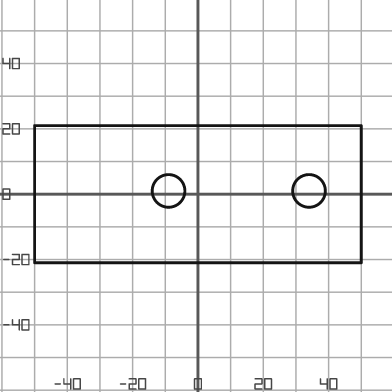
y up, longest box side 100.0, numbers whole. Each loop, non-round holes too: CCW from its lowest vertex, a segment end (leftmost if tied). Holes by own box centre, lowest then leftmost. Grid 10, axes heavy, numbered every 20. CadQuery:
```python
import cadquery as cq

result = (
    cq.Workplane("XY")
    .moveTo(-50.0, -21.0)
    .lineTo(50.0, -21.0)
    .lineTo(50.0, 21.0)
    .lineTo(-50.0, 21.0)
    .close()
    .moveTo(-9.0, 1.0)
    .circle(5.0)
    .moveTo(34.0, 1.0)
    .circle(5.0)
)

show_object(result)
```